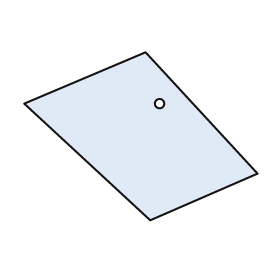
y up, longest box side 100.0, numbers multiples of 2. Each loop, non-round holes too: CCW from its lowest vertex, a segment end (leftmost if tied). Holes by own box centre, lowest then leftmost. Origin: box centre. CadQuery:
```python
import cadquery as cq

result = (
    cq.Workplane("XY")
    .moveTo(4.0, -36.0)
    .lineTo(50.0, -16.0)
    .lineTo(2.0, 36.0)
    .lineTo(-50.0, 14.0)
    .close()
    .moveTo(8.0, 14.0)
    .circle(2.0)
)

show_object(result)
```